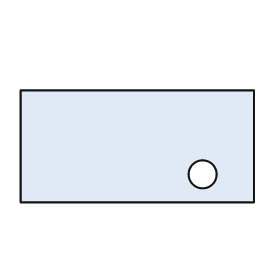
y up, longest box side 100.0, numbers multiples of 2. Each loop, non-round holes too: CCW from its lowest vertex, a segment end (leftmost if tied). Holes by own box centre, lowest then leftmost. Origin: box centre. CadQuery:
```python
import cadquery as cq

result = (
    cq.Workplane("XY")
    .moveTo(-50.0, -24.0)
    .lineTo(50.0, -24.0)
    .lineTo(50.0, 24.0)
    .lineTo(-50.0, 24.0)
    .close()
    .moveTo(28.0, -12.0)
    .circle(6.0)
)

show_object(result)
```